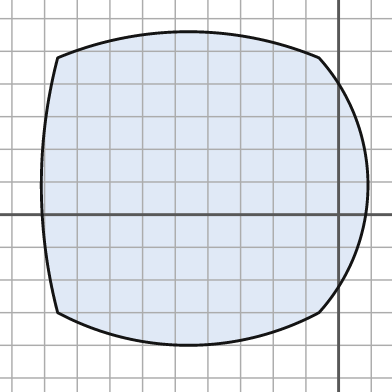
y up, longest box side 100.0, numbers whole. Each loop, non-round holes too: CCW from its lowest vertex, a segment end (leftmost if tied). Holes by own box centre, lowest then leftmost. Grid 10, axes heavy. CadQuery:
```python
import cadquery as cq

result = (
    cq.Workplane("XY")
    .moveTo(-86.0, -30.0)
    .threePointArc((-46.0, -40.0), (-6.0, -30.0))
    .threePointArc((9.0, 9.0), (-6.0, 48.0))
    .threePointArc((-46.0, 56.0), (-86.0, 48.0))
    .threePointArc((-91.0, 9.0), (-86.0, -30.0))
    .close()
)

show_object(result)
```